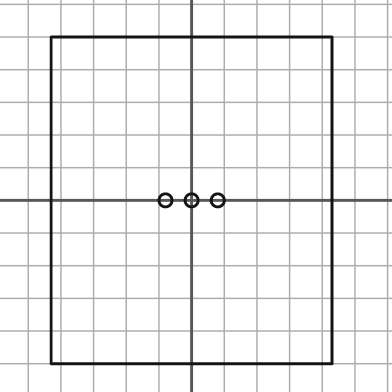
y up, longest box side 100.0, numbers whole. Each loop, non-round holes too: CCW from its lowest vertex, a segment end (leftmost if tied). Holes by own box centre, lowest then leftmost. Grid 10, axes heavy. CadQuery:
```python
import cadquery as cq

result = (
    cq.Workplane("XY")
    .moveTo(-43.0, -50.0)
    .lineTo(43.0, -50.0)
    .lineTo(43.0, 50.0)
    .lineTo(-43.0, 50.0)
    .close()
    .moveTo(-8.0, 0.0)
    .circle(2.0)
    .moveTo(0.0, 0.0)
    .circle(2.0)
    .moveTo(8.0, 0.0)
    .circle(2.0)
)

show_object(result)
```